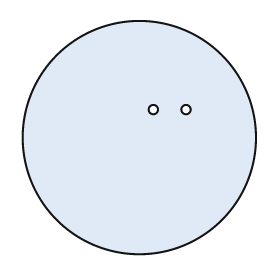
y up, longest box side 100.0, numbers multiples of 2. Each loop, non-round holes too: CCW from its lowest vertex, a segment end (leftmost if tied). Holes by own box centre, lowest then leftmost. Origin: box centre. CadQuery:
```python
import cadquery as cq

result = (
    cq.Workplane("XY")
    .moveTo(0.0, 0.0)
    .circle(50.0)
    .moveTo(6.0, 12.0)
    .circle(2.0)
    .moveTo(20.0, 12.0)
    .circle(2.0)
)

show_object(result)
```